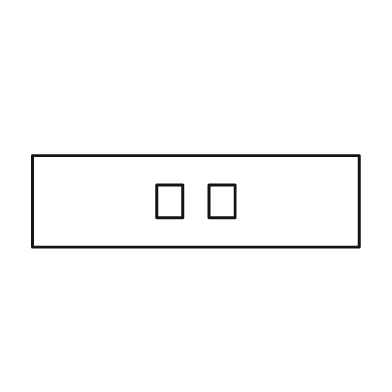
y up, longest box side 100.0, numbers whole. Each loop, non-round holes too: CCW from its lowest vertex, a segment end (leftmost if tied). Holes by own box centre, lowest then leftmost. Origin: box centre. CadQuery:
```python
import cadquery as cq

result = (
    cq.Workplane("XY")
    .moveTo(-50.0, -14.0)
    .lineTo(50.0, -14.0)
    .lineTo(50.0, 14.0)
    .lineTo(-50.0, 14.0)
    .close()
    .moveTo(-12.0, -5.0)
    .lineTo(-4.0, -5.0)
    .lineTo(-4.0, 5.0)
    .lineTo(-12.0, 5.0)
    .close()
    .moveTo(4.0, -5.0)
    .lineTo(12.0, -5.0)
    .lineTo(12.0, 5.0)
    .lineTo(4.0, 5.0)
    .close()
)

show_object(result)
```